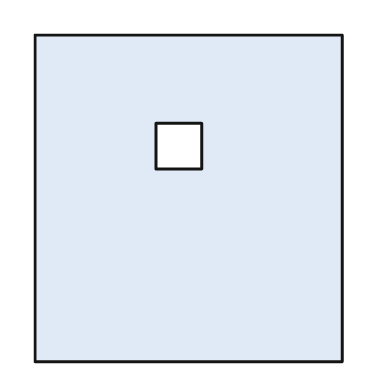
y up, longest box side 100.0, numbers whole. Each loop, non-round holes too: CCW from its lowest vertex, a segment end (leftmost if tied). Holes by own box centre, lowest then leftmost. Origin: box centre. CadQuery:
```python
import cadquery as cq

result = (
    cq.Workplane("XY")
    .moveTo(-47.0, -50.0)
    .lineTo(47.0, -50.0)
    .lineTo(47.0, 50.0)
    .lineTo(-47.0, 50.0)
    .close()
    .moveTo(-10.0, 9.0)
    .lineTo(4.0, 9.0)
    .lineTo(4.0, 23.0)
    .lineTo(-10.0, 23.0)
    .close()
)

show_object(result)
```